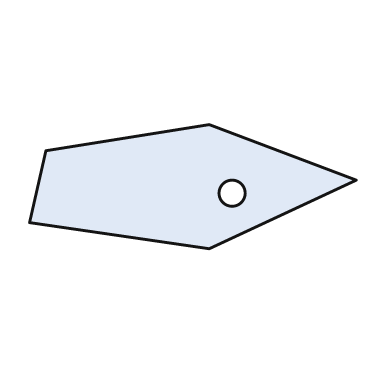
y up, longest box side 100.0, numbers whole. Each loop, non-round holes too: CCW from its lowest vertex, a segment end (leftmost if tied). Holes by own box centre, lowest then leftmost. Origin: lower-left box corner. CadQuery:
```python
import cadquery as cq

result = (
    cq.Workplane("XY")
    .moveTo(55.0, 0.0)
    .lineTo(100.0, 21.0)
    .lineTo(55.0, 38.0)
    .lineTo(5.0, 30.0)
    .lineTo(0.0, 8.0)
    .close()
    .moveTo(62.0, 17.0)
    .circle(4.0)
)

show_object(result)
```